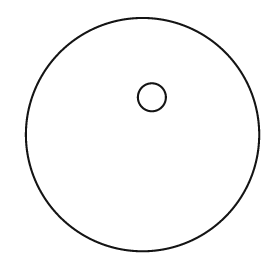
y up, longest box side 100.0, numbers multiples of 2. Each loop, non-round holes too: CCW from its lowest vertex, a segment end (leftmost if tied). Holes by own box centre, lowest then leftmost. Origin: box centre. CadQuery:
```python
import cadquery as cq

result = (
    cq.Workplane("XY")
    .moveTo(0.0, 0.0)
    .circle(50.0)
    .moveTo(4.0, 16.0)
    .circle(6.0)
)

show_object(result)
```